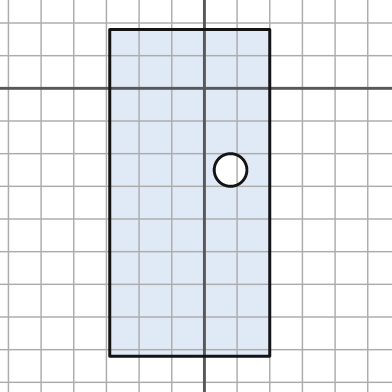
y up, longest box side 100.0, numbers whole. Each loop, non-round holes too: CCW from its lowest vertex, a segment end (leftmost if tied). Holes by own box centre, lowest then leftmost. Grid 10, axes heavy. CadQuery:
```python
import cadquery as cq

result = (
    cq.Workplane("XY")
    .moveTo(-29.0, -82.0)
    .lineTo(20.0, -82.0)
    .lineTo(20.0, 18.0)
    .lineTo(-29.0, 18.0)
    .close()
    .moveTo(8.0, -25.0)
    .circle(5.0)
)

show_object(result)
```